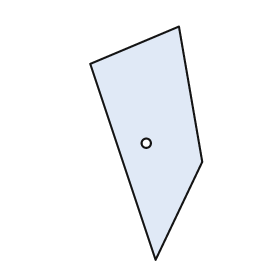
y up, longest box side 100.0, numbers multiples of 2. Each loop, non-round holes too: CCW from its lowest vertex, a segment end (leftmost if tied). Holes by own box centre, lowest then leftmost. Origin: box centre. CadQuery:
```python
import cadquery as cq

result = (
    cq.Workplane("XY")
    .moveTo(4.0, -50.0)
    .lineTo(24.0, -8.0)
    .lineTo(14.0, 50.0)
    .lineTo(-24.0, 34.0)
    .close()
    .moveTo(0.0, 0.0)
    .circle(2.0)
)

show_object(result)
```